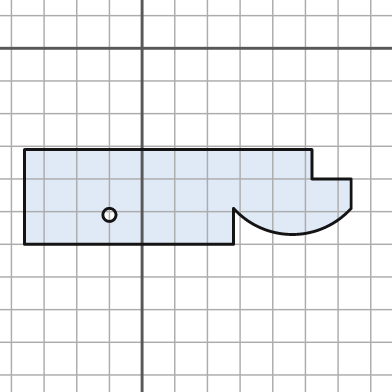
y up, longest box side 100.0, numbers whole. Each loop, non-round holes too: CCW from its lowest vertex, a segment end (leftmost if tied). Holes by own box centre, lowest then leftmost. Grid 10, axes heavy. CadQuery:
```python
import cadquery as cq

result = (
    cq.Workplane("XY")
    .moveTo(-36.0, -60.0)
    .lineTo(28.0, -60.0)
    .lineTo(28.0, -49.0)
    .threePointArc((46.0, -57.0), (64.0, -49.0))
    .lineTo(64.0, -40.0)
    .lineTo(52.0, -40.0)
    .lineTo(52.0, -31.0)
    .lineTo(-36.0, -31.0)
    .close()
    .moveTo(-10.0, -51.0)
    .circle(2.0)
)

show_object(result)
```